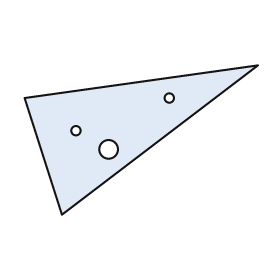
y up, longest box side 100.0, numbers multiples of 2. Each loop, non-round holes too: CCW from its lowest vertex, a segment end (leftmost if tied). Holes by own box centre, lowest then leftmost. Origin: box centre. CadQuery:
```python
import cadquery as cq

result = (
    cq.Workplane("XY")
    .moveTo(-34.0, -32.0)
    .lineTo(50.0, 32.0)
    .lineTo(-50.0, 18.0)
    .close()
    .moveTo(-14.0, -4.0)
    .circle(4.0)
    .moveTo(-28.0, 4.0)
    .circle(2.0)
    .moveTo(12.0, 18.0)
    .circle(2.0)
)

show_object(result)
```